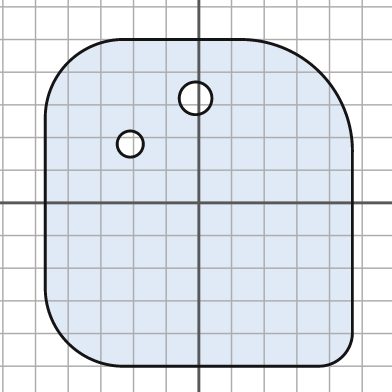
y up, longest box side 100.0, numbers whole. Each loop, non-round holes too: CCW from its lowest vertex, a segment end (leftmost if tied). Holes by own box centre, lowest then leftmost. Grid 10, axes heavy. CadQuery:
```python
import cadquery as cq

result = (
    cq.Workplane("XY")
    .moveTo(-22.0, -50.0)
    .lineTo(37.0, -50.0)
    .threePointArc((44.0, -47.0), (47.0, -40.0))
    .lineTo(47.0, 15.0)
    .threePointArc((37.0, 40.0), (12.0, 50.0))
    .lineTo(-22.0, 50.0)
    .threePointArc((-40.0, 43.0), (-47.0, 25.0))
    .lineTo(-47.0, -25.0)
    .threePointArc((-40.0, -43.0), (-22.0, -50.0))
    .close()
    .moveTo(-21.0, 18.0)
    .circle(4.0)
    .moveTo(-1.0, 32.0)
    .circle(5.0)
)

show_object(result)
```